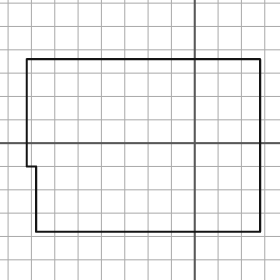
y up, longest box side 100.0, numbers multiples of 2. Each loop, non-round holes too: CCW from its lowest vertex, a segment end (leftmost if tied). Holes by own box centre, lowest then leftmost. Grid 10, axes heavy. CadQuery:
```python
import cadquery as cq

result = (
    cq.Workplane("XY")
    .moveTo(-68.0, -38.0)
    .lineTo(28.0, -38.0)
    .lineTo(28.0, 36.0)
    .lineTo(-72.0, 36.0)
    .lineTo(-72.0, -10.0)
    .lineTo(-68.0, -10.0)
    .close()
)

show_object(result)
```